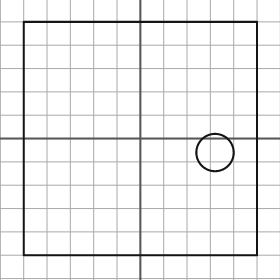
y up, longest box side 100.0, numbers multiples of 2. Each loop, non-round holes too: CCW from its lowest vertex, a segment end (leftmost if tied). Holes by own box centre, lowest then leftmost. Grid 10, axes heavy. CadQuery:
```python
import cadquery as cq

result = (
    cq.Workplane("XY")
    .moveTo(-50.0, -50.0)
    .lineTo(50.0, -50.0)
    .lineTo(50.0, 50.0)
    .lineTo(-50.0, 50.0)
    .close()
    .moveTo(32.0, -6.0)
    .circle(8.0)
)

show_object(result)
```